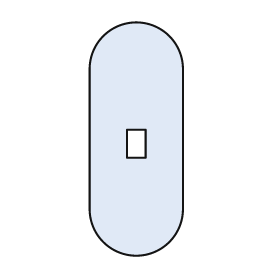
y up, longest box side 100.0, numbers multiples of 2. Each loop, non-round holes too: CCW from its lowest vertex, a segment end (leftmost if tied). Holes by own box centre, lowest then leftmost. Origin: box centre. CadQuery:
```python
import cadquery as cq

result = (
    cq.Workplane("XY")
    .moveTo(-20.0, -30.0)
    .threePointArc((0.0, -50.0), (20.0, -30.0))
    .lineTo(20.0, 30.0)
    .threePointArc((0.0, 50.0), (-20.0, 30.0))
    .close()
    .moveTo(-4.0, -8.0)
    .lineTo(4.0, -8.0)
    .lineTo(4.0, 4.0)
    .lineTo(-4.0, 4.0)
    .close()
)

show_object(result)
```